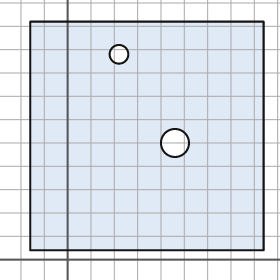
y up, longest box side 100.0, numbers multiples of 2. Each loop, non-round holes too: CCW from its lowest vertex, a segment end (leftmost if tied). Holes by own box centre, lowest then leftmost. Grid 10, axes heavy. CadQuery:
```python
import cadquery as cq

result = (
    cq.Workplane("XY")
    .moveTo(-16.0, 4.0)
    .lineTo(84.0, 4.0)
    .lineTo(84.0, 102.0)
    .lineTo(-16.0, 102.0)
    .close()
    .moveTo(46.0, 50.0)
    .circle(6.0)
    .moveTo(22.0, 88.0)
    .circle(4.0)
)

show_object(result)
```